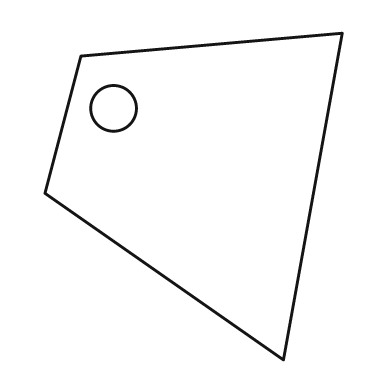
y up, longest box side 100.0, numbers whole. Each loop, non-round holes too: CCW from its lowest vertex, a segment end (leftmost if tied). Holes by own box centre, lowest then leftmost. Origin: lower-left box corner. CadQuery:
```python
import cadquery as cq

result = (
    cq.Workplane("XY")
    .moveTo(73.0, 0.0)
    .lineTo(91.0, 100.0)
    .lineTo(11.0, 93.0)
    .lineTo(0.0, 51.0)
    .close()
    .moveTo(21.0, 77.0)
    .circle(7.0)
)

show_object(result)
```